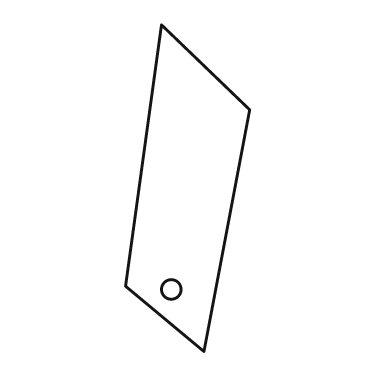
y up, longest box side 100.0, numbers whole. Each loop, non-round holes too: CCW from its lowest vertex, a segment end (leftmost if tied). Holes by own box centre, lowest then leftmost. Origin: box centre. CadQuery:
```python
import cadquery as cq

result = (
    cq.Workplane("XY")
    .moveTo(5.0, -50.0)
    .lineTo(19.0, 24.0)
    .lineTo(-8.0, 50.0)
    .lineTo(-19.0, -30.0)
    .close()
    .moveTo(-5.0, -31.0)
    .circle(3.0)
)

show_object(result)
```